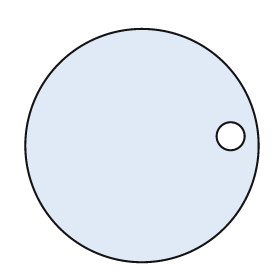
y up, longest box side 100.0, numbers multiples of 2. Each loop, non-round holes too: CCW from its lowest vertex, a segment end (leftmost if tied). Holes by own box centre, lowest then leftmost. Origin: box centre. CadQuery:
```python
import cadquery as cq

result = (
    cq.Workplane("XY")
    .moveTo(0.0, 0.0)
    .circle(50.0)
    .moveTo(38.0, 4.0)
    .circle(6.0)
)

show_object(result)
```